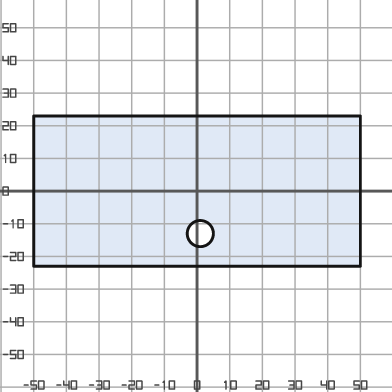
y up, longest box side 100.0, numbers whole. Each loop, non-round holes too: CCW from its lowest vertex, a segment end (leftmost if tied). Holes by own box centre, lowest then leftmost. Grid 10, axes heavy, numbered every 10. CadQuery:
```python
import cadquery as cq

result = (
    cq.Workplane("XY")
    .moveTo(-50.0, -23.0)
    .lineTo(50.0, -23.0)
    .lineTo(50.0, 23.0)
    .lineTo(-50.0, 23.0)
    .close()
    .moveTo(1.0, -13.0)
    .circle(4.0)
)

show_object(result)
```